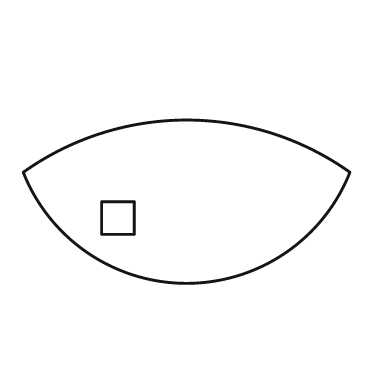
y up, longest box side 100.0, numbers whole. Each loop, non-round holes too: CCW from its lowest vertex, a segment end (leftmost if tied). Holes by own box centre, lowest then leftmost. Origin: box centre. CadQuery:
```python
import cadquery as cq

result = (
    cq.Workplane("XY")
    .moveTo(-50.0, 9.0)
    .threePointArc((0.0, -25.0), (50.0, 9.0))
    .threePointArc((0.0, 25.0), (-50.0, 9.0))
    .close()
    .moveTo(-26.0, -10.0)
    .lineTo(-16.0, -10.0)
    .lineTo(-16.0, 0.0)
    .lineTo(-26.0, 0.0)
    .close()
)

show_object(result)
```